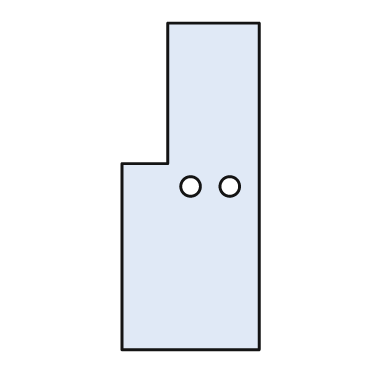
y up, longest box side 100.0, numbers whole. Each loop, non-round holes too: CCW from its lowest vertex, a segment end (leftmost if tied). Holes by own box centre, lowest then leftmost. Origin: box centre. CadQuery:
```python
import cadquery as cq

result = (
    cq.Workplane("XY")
    .moveTo(-21.0, -50.0)
    .lineTo(21.0, -50.0)
    .lineTo(21.0, 50.0)
    .lineTo(-7.0, 50.0)
    .lineTo(-7.0, 7.0)
    .lineTo(-21.0, 7.0)
    .close()
    .moveTo(0.0, 0.0)
    .circle(3.0)
    .moveTo(12.0, 0.0)
    .circle(3.0)
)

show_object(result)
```